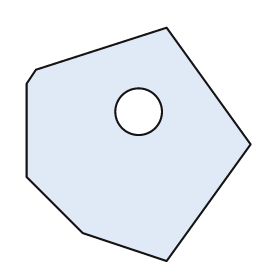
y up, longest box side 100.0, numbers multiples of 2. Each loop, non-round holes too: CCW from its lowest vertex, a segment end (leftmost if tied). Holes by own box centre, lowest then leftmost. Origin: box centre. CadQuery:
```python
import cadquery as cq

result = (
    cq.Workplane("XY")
    .moveTo(12.0, -50.0)
    .lineTo(48.0, 0.0)
    .lineTo(12.0, 50.0)
    .lineTo(-44.0, 32.0)
    .lineTo(-48.0, 26.0)
    .lineTo(-48.0, -14.0)
    .lineTo(-24.0, -38.0)
    .close()
    .moveTo(0.0, 14.0)
    .circle(10.0)
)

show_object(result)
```